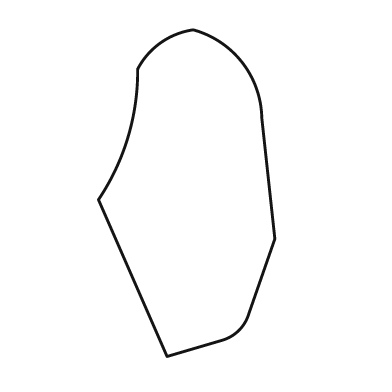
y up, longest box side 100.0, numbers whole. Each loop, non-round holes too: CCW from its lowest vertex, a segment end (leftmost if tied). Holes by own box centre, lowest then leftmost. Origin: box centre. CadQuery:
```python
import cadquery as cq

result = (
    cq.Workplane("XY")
    .moveTo(-6.0, -50.0)
    .lineTo(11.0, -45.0)
    .threePointArc((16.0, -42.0), (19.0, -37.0))
    .lineTo(27.0, -14.0)
    .lineTo(23.0, 23.0)
    .threePointArc((17.0, 40.0), (2.0, 50.0))
    .threePointArc((-8.0, 46.0), (-15.0, 38.0))
    .threePointArc((-18.0, 17.0), (-27.0, -2.0))
    .close()
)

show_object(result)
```